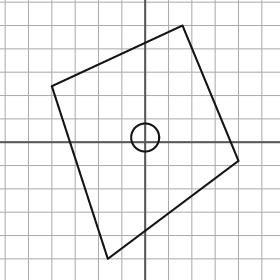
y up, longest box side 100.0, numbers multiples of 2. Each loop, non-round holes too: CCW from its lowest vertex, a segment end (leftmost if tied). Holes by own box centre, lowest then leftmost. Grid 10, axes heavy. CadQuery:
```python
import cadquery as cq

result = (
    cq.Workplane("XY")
    .moveTo(-16.0, -50.0)
    .lineTo(40.0, -8.0)
    .lineTo(16.0, 50.0)
    .lineTo(-40.0, 24.0)
    .close()
    .moveTo(0.0, 2.0)
    .circle(6.0)
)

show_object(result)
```